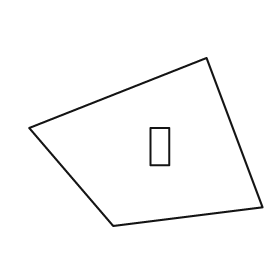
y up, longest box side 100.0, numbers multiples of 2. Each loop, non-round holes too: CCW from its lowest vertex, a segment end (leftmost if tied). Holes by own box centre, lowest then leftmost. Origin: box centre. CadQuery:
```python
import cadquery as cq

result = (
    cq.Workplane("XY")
    .moveTo(-14.0, -36.0)
    .lineTo(50.0, -28.0)
    .lineTo(26.0, 36.0)
    .lineTo(-50.0, 6.0)
    .close()
    .moveTo(2.0, -10.0)
    .lineTo(10.0, -10.0)
    .lineTo(10.0, 6.0)
    .lineTo(2.0, 6.0)
    .close()
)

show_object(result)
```